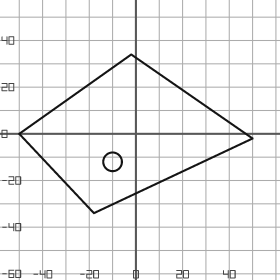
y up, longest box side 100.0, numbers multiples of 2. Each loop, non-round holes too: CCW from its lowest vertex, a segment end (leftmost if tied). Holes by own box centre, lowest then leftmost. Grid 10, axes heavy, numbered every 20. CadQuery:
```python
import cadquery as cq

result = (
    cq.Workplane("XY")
    .moveTo(-18.0, -34.0)
    .lineTo(50.0, -2.0)
    .lineTo(-2.0, 34.0)
    .lineTo(-50.0, 0.0)
    .close()
    .moveTo(-10.0, -12.0)
    .circle(4.0)
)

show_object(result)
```